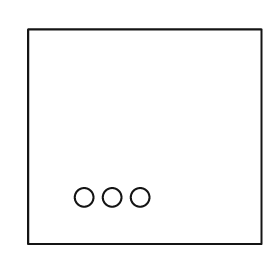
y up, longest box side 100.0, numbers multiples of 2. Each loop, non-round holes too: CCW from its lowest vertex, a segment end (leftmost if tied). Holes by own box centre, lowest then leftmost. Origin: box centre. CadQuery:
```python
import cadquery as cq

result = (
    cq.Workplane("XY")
    .moveTo(-50.0, -46.0)
    .lineTo(50.0, -46.0)
    .lineTo(50.0, 46.0)
    .lineTo(-50.0, 46.0)
    .close()
    .moveTo(-26.0, -26.0)
    .circle(4.0)
    .moveTo(-14.0, -26.0)
    .circle(4.0)
    .moveTo(-2.0, -26.0)
    .circle(4.0)
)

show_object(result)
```